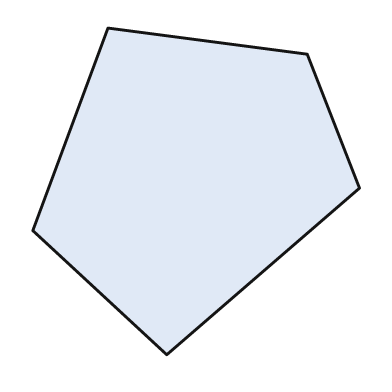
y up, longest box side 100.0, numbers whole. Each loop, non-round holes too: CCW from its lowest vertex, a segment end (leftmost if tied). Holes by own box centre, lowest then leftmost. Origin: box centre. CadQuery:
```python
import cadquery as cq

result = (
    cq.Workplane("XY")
    .moveTo(-9.0, -50.0)
    .lineTo(50.0, 1.0)
    .lineTo(34.0, 42.0)
    .lineTo(-27.0, 50.0)
    .lineTo(-50.0, -12.0)
    .close()
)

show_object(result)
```